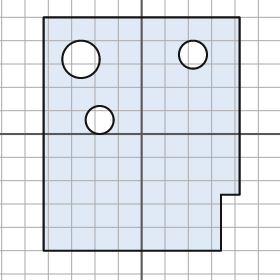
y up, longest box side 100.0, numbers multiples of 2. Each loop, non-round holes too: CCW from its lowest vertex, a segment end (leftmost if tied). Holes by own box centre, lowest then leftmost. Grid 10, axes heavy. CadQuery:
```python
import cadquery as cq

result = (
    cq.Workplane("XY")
    .moveTo(-42.0, -50.0)
    .lineTo(34.0, -50.0)
    .lineTo(34.0, -26.0)
    .lineTo(42.0, -26.0)
    .lineTo(42.0, 50.0)
    .lineTo(-42.0, 50.0)
    .close()
    .moveTo(-18.0, 6.0)
    .circle(6.0)
    .moveTo(-26.0, 32.0)
    .circle(8.0)
    .moveTo(22.0, 34.0)
    .circle(6.0)
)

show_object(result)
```